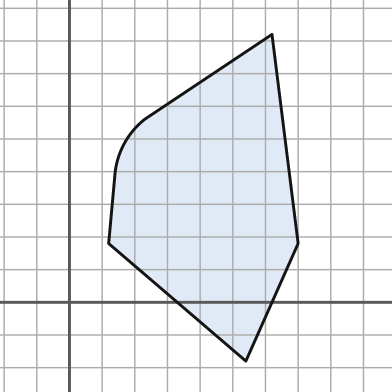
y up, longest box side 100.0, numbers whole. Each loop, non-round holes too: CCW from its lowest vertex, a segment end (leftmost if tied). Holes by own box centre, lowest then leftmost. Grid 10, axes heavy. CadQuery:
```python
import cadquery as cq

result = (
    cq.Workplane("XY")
    .moveTo(54.0, -18.0)
    .lineTo(70.0, 18.0)
    .lineTo(62.0, 82.0)
    .lineTo(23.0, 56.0)
    .threePointArc((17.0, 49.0), (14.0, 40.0))
    .lineTo(12.0, 18.0)
    .close()
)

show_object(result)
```